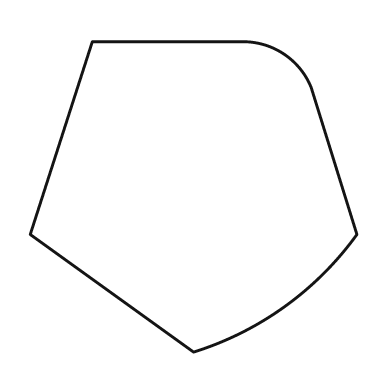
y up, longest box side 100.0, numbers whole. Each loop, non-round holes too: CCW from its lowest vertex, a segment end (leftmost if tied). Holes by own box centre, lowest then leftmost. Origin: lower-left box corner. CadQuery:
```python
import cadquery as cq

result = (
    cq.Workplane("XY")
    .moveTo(50.0, 0.0)
    .threePointArc((78.0, 14.0), (100.0, 36.0))
    .lineTo(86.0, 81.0)
    .threePointArc((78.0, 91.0), (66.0, 95.0))
    .lineTo(19.0, 95.0)
    .lineTo(0.0, 36.0)
    .close()
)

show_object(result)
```